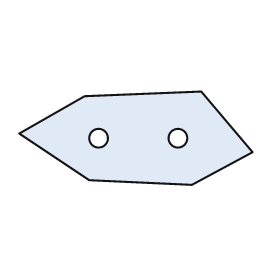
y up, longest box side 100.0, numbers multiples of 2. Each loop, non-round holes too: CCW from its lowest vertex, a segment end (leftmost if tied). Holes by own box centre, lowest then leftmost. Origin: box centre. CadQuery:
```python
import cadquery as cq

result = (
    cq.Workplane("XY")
    .moveTo(24.0, -20.0)
    .lineTo(50.0, -6.0)
    .lineTo(28.0, 20.0)
    .lineTo(-22.0, 18.0)
    .lineTo(-50.0, 2.0)
    .lineTo(-20.0, -18.0)
    .close()
    .moveTo(-16.0, 0.0)
    .circle(4.0)
    .moveTo(18.0, 0.0)
    .circle(4.0)
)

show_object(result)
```